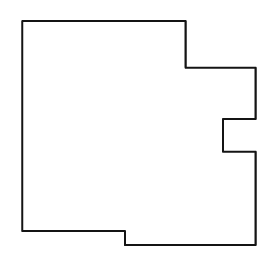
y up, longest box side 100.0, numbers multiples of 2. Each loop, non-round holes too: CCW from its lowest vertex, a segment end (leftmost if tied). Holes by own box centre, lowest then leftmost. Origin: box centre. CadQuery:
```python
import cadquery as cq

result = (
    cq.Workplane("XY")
    .moveTo(-6.0, -48.0)
    .lineTo(50.0, -48.0)
    .lineTo(50.0, -8.0)
    .lineTo(36.0, -8.0)
    .lineTo(36.0, 6.0)
    .lineTo(50.0, 6.0)
    .lineTo(50.0, 28.0)
    .lineTo(20.0, 28.0)
    .lineTo(20.0, 48.0)
    .lineTo(-50.0, 48.0)
    .lineTo(-50.0, -42.0)
    .lineTo(-6.0, -42.0)
    .close()
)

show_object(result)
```